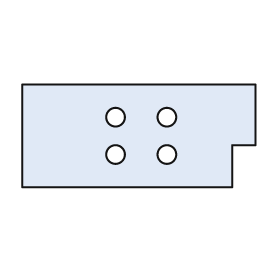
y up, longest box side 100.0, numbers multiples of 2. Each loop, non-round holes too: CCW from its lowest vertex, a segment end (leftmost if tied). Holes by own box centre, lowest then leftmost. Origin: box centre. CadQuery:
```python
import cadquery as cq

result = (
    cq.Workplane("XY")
    .moveTo(-50.0, -22.0)
    .lineTo(40.0, -22.0)
    .lineTo(40.0, -4.0)
    .lineTo(50.0, -4.0)
    .lineTo(50.0, 22.0)
    .lineTo(-50.0, 22.0)
    .close()
    .moveTo(-10.0, -8.0)
    .circle(4.0)
    .moveTo(12.0, -8.0)
    .circle(4.0)
    .moveTo(-10.0, 8.0)
    .circle(4.0)
    .moveTo(12.0, 8.0)
    .circle(4.0)
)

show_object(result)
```